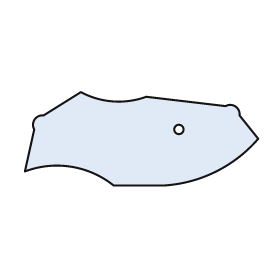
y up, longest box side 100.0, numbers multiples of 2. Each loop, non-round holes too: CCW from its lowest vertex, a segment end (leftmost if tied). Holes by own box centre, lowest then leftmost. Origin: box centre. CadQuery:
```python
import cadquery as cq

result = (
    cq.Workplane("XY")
    .moveTo(-12.0, -20.0)
    .lineTo(10.0, -20.0)
    .threePointArc((32.0, -14.0), (50.0, 0.0))
    .lineTo(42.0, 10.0)
    .threePointArc((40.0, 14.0), (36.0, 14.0))
    .lineTo(2.0, 18.0)
    .threePointArc((-12.0, 16.0), (-26.0, 20.0))
    .lineTo(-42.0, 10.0)
    .threePointArc((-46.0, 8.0), (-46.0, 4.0))
    .lineTo(-50.0, -14.0)
    .threePointArc((-30.0, -12.0), (-12.0, -20.0))
    .close()
    .moveTo(16.0, 4.0)
    .circle(2.0)
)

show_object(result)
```